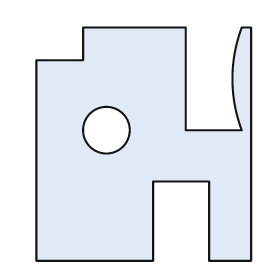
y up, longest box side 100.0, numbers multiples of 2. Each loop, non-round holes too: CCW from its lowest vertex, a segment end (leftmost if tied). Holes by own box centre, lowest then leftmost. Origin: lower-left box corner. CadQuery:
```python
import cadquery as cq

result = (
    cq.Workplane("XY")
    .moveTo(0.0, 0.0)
    .lineTo(50.0, 0.0)
    .lineTo(50.0, 34.0)
    .lineTo(74.0, 34.0)
    .lineTo(74.0, 0.0)
    .lineTo(92.0, 0.0)
    .lineTo(92.0, 100.0)
    .lineTo(88.0, 100.0)
    .threePointArc((84.0, 78.0), (88.0, 56.0))
    .lineTo(64.0, 56.0)
    .lineTo(64.0, 100.0)
    .lineTo(20.0, 100.0)
    .lineTo(20.0, 86.0)
    .lineTo(0.0, 86.0)
    .close()
    .moveTo(30.0, 56.0)
    .circle(10.0)
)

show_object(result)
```